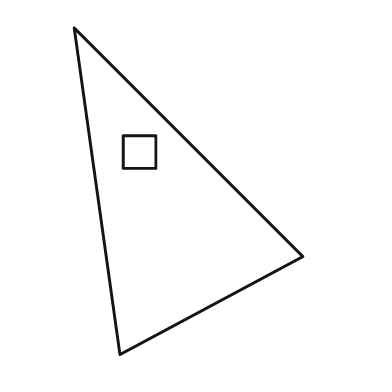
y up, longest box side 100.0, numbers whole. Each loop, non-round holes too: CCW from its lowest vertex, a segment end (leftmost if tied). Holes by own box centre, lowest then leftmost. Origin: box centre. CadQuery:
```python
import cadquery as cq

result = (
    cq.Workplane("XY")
    .moveTo(-21.0, -50.0)
    .lineTo(35.0, -20.0)
    .lineTo(-35.0, 50.0)
    .close()
    .moveTo(-20.0, 7.0)
    .lineTo(-10.0, 7.0)
    .lineTo(-10.0, 17.0)
    .lineTo(-20.0, 17.0)
    .close()
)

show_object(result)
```